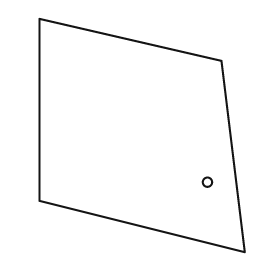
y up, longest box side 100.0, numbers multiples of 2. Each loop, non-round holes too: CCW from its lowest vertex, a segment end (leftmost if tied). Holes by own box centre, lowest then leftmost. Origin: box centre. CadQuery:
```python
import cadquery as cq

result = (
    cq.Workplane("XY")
    .moveTo(44.0, -50.0)
    .lineTo(34.0, 32.0)
    .lineTo(-44.0, 50.0)
    .lineTo(-44.0, -28.0)
    .close()
    .moveTo(28.0, -20.0)
    .circle(2.0)
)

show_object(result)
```